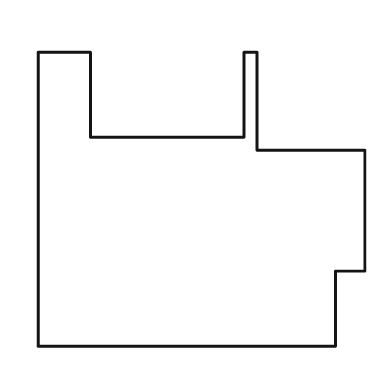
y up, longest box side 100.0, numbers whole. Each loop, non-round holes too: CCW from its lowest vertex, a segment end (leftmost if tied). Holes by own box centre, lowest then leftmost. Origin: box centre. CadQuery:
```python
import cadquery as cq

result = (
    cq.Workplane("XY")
    .moveTo(-50.0, -45.0)
    .lineTo(41.0, -45.0)
    .lineTo(41.0, -22.0)
    .lineTo(50.0, -22.0)
    .lineTo(50.0, 15.0)
    .lineTo(17.0, 15.0)
    .lineTo(17.0, 45.0)
    .lineTo(13.0, 45.0)
    .lineTo(13.0, 19.0)
    .lineTo(-34.0, 19.0)
    .lineTo(-34.0, 45.0)
    .lineTo(-50.0, 45.0)
    .close()
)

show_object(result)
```